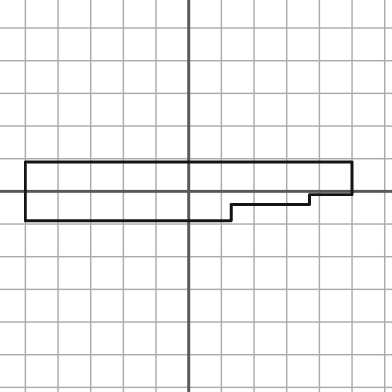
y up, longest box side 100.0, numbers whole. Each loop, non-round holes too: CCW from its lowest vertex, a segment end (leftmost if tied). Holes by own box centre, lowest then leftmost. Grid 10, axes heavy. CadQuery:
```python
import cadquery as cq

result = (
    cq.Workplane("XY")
    .moveTo(-50.0, -9.0)
    .lineTo(13.0, -9.0)
    .lineTo(13.0, -4.0)
    .lineTo(37.0, -4.0)
    .lineTo(37.0, -1.0)
    .lineTo(50.0, -1.0)
    .lineTo(50.0, 9.0)
    .lineTo(-50.0, 9.0)
    .close()
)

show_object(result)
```